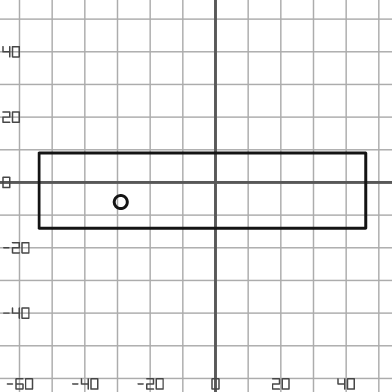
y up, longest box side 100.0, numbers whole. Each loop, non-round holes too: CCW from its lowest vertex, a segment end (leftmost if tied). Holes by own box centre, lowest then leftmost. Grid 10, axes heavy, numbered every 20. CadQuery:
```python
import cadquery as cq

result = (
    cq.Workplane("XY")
    .moveTo(-54.0, -14.0)
    .lineTo(46.0, -14.0)
    .lineTo(46.0, 9.0)
    .lineTo(-54.0, 9.0)
    .close()
    .moveTo(-29.0, -6.0)
    .circle(2.0)
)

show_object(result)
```